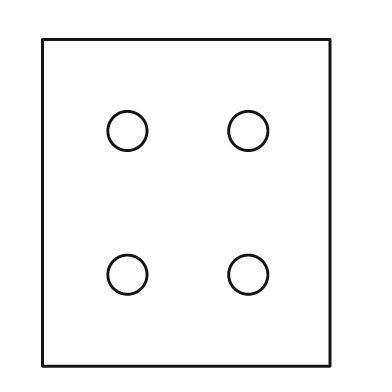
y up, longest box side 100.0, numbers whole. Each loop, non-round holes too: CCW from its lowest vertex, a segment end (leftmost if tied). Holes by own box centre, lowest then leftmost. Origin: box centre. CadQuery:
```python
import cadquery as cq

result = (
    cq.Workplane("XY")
    .moveTo(-44.0, -50.0)
    .lineTo(44.0, -50.0)
    .lineTo(44.0, 50.0)
    .lineTo(-44.0, 50.0)
    .close()
    .moveTo(-18.0, -22.0)
    .circle(6.0)
    .moveTo(19.0, -22.0)
    .circle(6.0)
    .moveTo(-18.0, 22.0)
    .circle(6.0)
    .moveTo(19.0, 22.0)
    .circle(6.0)
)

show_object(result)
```